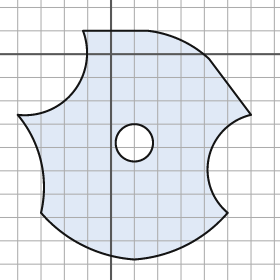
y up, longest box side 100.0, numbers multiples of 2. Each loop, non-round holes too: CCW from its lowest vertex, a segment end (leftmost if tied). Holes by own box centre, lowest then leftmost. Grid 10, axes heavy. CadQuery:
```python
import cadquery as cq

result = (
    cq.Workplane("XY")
    .moveTo(10.0, -88.0)
    .threePointArc((32.0, -82.0), (50.0, -68.0))
    .threePointArc((42.0, -44.0), (60.0, -26.0))
    .lineTo(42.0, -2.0)
    .threePointArc((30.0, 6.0), (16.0, 10.0))
    .lineTo(-12.0, 10.0)
    .threePointArc((-16.0, -16.0), (-40.0, -26.0))
    .threePointArc((-30.0, -46.0), (-30.0, -68.0))
    .threePointArc((-12.0, -82.0), (10.0, -88.0))
    .close()
    .moveTo(10.0, -38.0)
    .circle(8.0)
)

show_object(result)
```